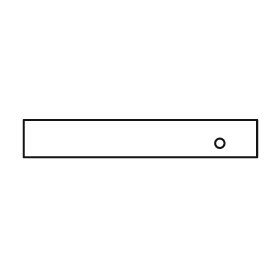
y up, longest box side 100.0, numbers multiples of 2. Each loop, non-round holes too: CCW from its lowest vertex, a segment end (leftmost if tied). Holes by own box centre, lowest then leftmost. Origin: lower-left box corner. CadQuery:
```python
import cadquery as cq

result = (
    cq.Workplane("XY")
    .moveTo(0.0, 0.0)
    .lineTo(100.0, 0.0)
    .lineTo(100.0, 16.0)
    .lineTo(0.0, 16.0)
    .close()
    .moveTo(84.0, 6.0)
    .circle(2.0)
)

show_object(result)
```